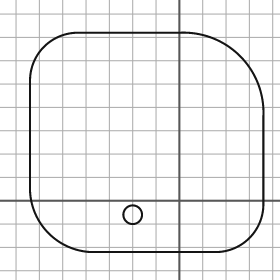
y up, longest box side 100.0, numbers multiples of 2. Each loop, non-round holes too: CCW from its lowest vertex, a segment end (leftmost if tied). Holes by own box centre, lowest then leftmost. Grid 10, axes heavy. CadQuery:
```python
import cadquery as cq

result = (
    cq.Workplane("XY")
    .moveTo(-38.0, -22.0)
    .lineTo(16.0, -22.0)
    .threePointArc((30.0, -16.0), (36.0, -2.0))
    .lineTo(36.0, 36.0)
    .threePointArc((26.0, 62.0), (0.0, 72.0))
    .lineTo(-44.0, 72.0)
    .threePointArc((-58.0, 66.0), (-64.0, 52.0))
    .lineTo(-64.0, 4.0)
    .threePointArc((-56.0, -14.0), (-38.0, -22.0))
    .close()
    .moveTo(-20.0, -6.0)
    .circle(4.0)
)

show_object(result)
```